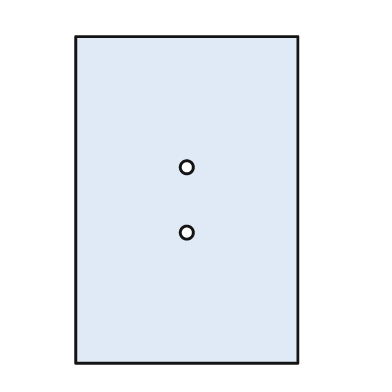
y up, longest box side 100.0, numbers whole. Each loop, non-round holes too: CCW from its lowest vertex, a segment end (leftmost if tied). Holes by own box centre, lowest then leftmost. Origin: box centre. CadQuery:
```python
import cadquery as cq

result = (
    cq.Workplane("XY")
    .moveTo(-34.0, -50.0)
    .lineTo(34.0, -50.0)
    .lineTo(34.0, 50.0)
    .lineTo(-34.0, 50.0)
    .close()
    .moveTo(0.0, -10.0)
    .circle(2.0)
    .moveTo(0.0, 10.0)
    .circle(2.0)
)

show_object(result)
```